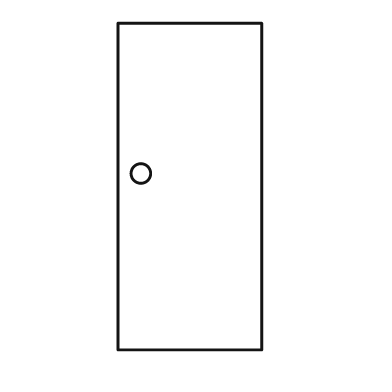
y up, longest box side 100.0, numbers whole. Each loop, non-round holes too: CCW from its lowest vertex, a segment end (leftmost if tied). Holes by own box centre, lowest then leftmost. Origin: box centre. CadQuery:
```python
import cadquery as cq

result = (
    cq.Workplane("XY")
    .moveTo(-22.0, -50.0)
    .lineTo(22.0, -50.0)
    .lineTo(22.0, 50.0)
    .lineTo(-22.0, 50.0)
    .close()
    .moveTo(-15.0, 4.0)
    .circle(3.0)
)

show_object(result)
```